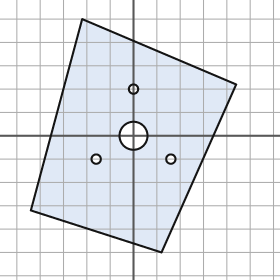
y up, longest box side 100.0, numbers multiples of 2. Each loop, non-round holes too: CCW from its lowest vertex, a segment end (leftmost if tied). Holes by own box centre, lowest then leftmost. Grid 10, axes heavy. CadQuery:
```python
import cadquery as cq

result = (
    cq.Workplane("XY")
    .moveTo(12.0, -50.0)
    .lineTo(44.0, 22.0)
    .lineTo(-22.0, 50.0)
    .lineTo(-44.0, -32.0)
    .close()
    .moveTo(-16.0, -10.0)
    .circle(2.0)
    .moveTo(16.0, -10.0)
    .circle(2.0)
    .moveTo(0.0, 0.0)
    .circle(6.0)
    .moveTo(0.0, 20.0)
    .circle(2.0)
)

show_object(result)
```